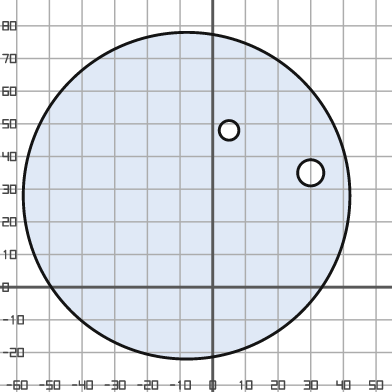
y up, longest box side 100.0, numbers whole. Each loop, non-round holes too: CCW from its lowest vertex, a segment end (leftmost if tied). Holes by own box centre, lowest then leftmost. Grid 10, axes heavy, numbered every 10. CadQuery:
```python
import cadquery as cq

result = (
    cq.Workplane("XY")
    .moveTo(-8.0, 28.0)
    .circle(50.0)
    .moveTo(30.0, 35.0)
    .circle(4.0)
    .moveTo(5.0, 48.0)
    .circle(3.0)
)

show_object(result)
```